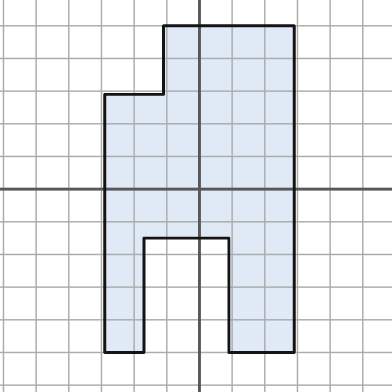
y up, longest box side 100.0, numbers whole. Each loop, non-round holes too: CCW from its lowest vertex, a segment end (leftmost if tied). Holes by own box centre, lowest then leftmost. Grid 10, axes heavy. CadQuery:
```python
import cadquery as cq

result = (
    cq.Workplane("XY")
    .moveTo(-29.0, -50.0)
    .lineTo(-17.0, -50.0)
    .lineTo(-17.0, -15.0)
    .lineTo(9.0, -15.0)
    .lineTo(9.0, -50.0)
    .lineTo(29.0, -50.0)
    .lineTo(29.0, 50.0)
    .lineTo(-11.0, 50.0)
    .lineTo(-11.0, 29.0)
    .lineTo(-29.0, 29.0)
    .close()
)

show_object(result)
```